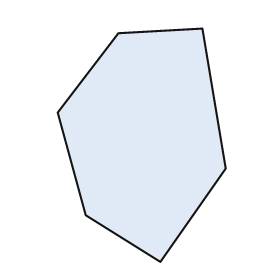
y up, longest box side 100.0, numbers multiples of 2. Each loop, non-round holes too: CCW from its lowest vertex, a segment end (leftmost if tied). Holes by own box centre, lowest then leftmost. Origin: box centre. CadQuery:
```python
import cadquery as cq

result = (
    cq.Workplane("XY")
    .moveTo(8.0, -50.0)
    .lineTo(36.0, -10.0)
    .lineTo(26.0, 50.0)
    .lineTo(-10.0, 48.0)
    .lineTo(-36.0, 14.0)
    .lineTo(-24.0, -30.0)
    .close()
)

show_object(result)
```